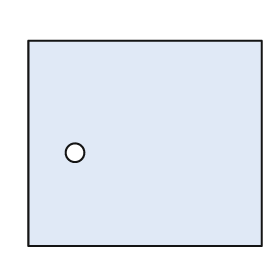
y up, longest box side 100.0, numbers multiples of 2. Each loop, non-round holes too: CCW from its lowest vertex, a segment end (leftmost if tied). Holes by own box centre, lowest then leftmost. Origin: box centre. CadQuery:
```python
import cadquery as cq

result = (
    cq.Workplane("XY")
    .moveTo(-50.0, -44.0)
    .lineTo(50.0, -44.0)
    .lineTo(50.0, 44.0)
    .lineTo(-50.0, 44.0)
    .close()
    .moveTo(-30.0, -4.0)
    .circle(4.0)
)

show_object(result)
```